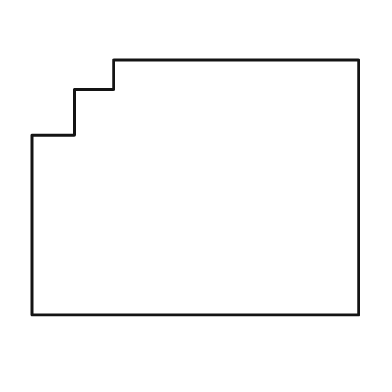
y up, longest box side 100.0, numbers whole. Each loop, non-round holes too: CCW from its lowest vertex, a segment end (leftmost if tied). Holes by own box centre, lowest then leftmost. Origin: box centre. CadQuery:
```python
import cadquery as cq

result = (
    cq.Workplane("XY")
    .moveTo(-50.0, -39.0)
    .lineTo(50.0, -39.0)
    .lineTo(50.0, 39.0)
    .lineTo(-25.0, 39.0)
    .lineTo(-25.0, 30.0)
    .lineTo(-37.0, 30.0)
    .lineTo(-37.0, 16.0)
    .lineTo(-50.0, 16.0)
    .close()
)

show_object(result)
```